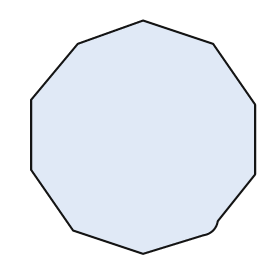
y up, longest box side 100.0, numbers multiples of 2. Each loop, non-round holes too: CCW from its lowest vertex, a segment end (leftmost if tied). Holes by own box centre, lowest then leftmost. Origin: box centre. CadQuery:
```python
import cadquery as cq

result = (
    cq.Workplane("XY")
    .moveTo(0.0, -50.0)
    .lineTo(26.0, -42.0)
    .threePointArc((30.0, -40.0), (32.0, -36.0))
    .lineTo(48.0, -16.0)
    .lineTo(48.0, 14.0)
    .lineTo(30.0, 40.0)
    .lineTo(0.0, 50.0)
    .lineTo(-28.0, 40.0)
    .lineTo(-48.0, 16.0)
    .lineTo(-48.0, -14.0)
    .lineTo(-30.0, -40.0)
    .close()
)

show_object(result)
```